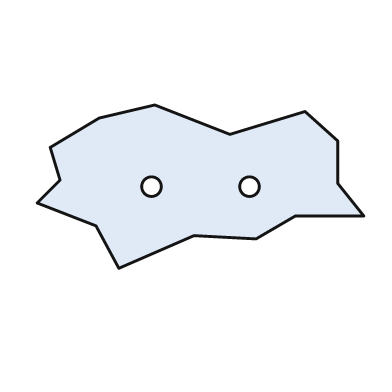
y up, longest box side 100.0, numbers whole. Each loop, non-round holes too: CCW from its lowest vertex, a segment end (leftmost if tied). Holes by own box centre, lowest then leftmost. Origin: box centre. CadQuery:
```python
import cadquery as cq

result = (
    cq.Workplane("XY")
    .moveTo(-25.0, -25.0)
    .lineTo(-2.0, -15.0)
    .lineTo(17.0, -16.0)
    .lineTo(29.0, -9.0)
    .lineTo(50.0, -9.0)
    .lineTo(42.0, 1.0)
    .lineTo(42.0, 14.0)
    .lineTo(32.0, 23.0)
    .lineTo(9.0, 16.0)
    .lineTo(-14.0, 25.0)
    .lineTo(-31.0, 21.0)
    .lineTo(-46.0, 12.0)
    .lineTo(-43.0, 2.0)
    .lineTo(-50.0, -5.0)
    .lineTo(-32.0, -12.0)
    .close()
    .moveTo(-15.0, 0.0)
    .circle(3.0)
    .moveTo(15.0, 0.0)
    .circle(3.0)
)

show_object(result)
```